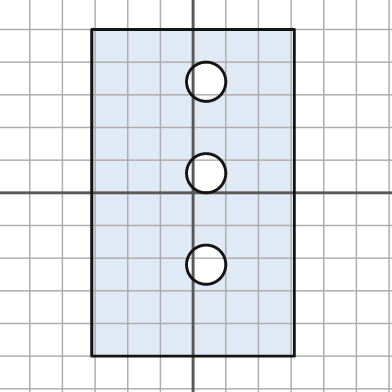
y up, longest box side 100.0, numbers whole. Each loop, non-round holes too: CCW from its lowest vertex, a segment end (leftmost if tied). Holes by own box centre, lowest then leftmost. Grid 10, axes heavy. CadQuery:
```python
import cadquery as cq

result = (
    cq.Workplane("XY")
    .moveTo(-31.0, -50.0)
    .lineTo(31.0, -50.0)
    .lineTo(31.0, 50.0)
    .lineTo(-31.0, 50.0)
    .close()
    .moveTo(4.0, -22.0)
    .circle(6.0)
    .moveTo(4.0, 6.0)
    .circle(6.0)
    .moveTo(4.0, 34.0)
    .circle(6.0)
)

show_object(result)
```